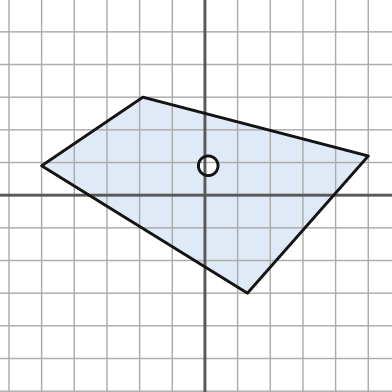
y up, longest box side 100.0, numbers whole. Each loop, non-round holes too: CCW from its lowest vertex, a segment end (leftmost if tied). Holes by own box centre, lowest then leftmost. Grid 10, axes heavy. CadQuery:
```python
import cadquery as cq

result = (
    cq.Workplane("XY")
    .moveTo(13.0, -30.0)
    .lineTo(50.0, 12.0)
    .lineTo(-19.0, 30.0)
    .lineTo(-50.0, 9.0)
    .close()
    .moveTo(1.0, 9.0)
    .circle(3.0)
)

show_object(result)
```